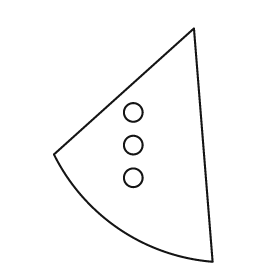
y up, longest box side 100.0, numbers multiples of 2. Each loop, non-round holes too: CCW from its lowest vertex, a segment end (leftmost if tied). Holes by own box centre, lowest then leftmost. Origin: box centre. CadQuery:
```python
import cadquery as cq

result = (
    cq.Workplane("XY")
    .moveTo(34.0, -50.0)
    .lineTo(26.0, 50.0)
    .lineTo(-34.0, -4.0)
    .threePointArc((-6.0, -36.0), (34.0, -50.0))
    .close()
    .moveTo(0.0, -14.0)
    .circle(4.0)
    .moveTo(0.0, 0.0)
    .circle(4.0)
    .moveTo(0.0, 14.0)
    .circle(4.0)
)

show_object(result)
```